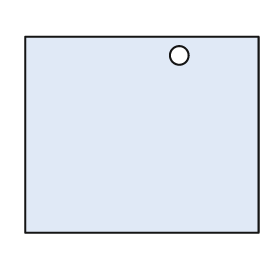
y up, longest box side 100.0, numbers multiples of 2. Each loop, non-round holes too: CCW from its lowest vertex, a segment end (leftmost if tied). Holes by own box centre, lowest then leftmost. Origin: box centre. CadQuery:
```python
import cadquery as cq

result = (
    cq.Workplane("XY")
    .moveTo(-50.0, -42.0)
    .lineTo(50.0, -42.0)
    .lineTo(50.0, 42.0)
    .lineTo(-50.0, 42.0)
    .close()
    .moveTo(16.0, 34.0)
    .circle(4.0)
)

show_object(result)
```